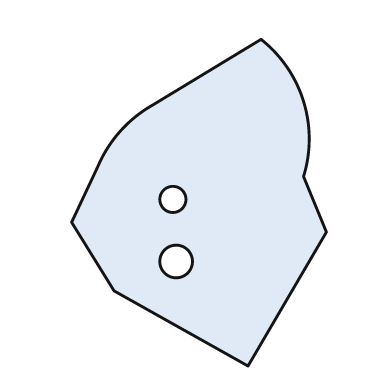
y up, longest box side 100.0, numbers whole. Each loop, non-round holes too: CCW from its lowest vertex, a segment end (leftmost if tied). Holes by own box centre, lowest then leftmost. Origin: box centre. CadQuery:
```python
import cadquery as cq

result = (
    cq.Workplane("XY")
    .moveTo(15.0, -50.0)
    .lineTo(39.0, -9.0)
    .lineTo(32.0, 8.0)
    .threePointArc((32.0, 31.0), (19.0, 50.0))
    .lineTo(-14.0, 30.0)
    .threePointArc((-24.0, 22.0), (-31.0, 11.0))
    .lineTo(-39.0, -6.0)
    .lineTo(-26.0, -27.0)
    .close()
    .moveTo(-7.0, -18.0)
    .circle(5.0)
    .moveTo(-8.0, 1.0)
    .circle(4.0)
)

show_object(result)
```